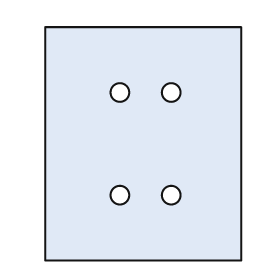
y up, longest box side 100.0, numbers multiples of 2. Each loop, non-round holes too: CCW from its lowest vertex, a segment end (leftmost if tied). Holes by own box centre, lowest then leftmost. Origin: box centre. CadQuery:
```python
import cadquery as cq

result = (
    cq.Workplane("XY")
    .moveTo(-42.0, -50.0)
    .lineTo(42.0, -50.0)
    .lineTo(42.0, 50.0)
    .lineTo(-42.0, 50.0)
    .close()
    .moveTo(-10.0, -22.0)
    .circle(4.0)
    .moveTo(12.0, -22.0)
    .circle(4.0)
    .moveTo(-10.0, 22.0)
    .circle(4.0)
    .moveTo(12.0, 22.0)
    .circle(4.0)
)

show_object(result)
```